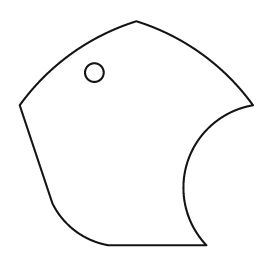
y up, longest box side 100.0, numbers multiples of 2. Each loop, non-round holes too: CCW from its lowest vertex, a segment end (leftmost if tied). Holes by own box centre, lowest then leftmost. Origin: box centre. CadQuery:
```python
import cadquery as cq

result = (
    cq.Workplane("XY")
    .moveTo(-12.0, -48.0)
    .lineTo(30.0, -48.0)
    .threePointArc((22.0, -12.0), (50.0, 12.0))
    .threePointArc((28.0, 34.0), (0.0, 48.0))
    .threePointArc((-28.0, 34.0), (-50.0, 12.0))
    .lineTo(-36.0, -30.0)
    .threePointArc((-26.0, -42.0), (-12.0, -48.0))
    .close()
    .moveTo(-18.0, 26.0)
    .circle(4.0)
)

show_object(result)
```